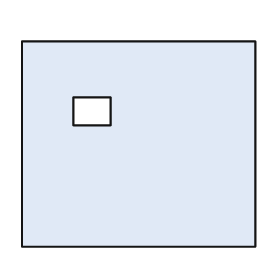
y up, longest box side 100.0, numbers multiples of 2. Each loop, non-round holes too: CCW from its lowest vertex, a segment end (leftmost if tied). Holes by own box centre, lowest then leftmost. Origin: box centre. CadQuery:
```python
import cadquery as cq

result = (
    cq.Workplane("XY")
    .moveTo(-50.0, -44.0)
    .lineTo(50.0, -44.0)
    .lineTo(50.0, 44.0)
    .lineTo(-50.0, 44.0)
    .close()
    .moveTo(-28.0, 8.0)
    .lineTo(-12.0, 8.0)
    .lineTo(-12.0, 20.0)
    .lineTo(-28.0, 20.0)
    .close()
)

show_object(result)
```